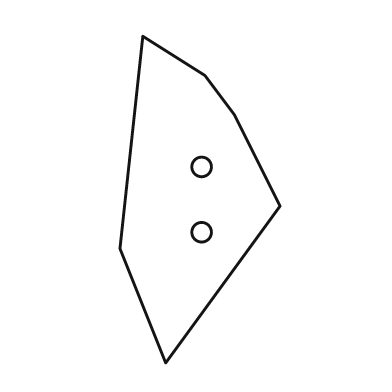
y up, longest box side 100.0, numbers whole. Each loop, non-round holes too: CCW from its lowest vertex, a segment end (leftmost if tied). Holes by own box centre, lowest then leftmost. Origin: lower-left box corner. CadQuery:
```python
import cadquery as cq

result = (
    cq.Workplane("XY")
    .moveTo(14.0, 0.0)
    .lineTo(49.0, 48.0)
    .lineTo(35.0, 76.0)
    .lineTo(26.0, 88.0)
    .lineTo(7.0, 100.0)
    .lineTo(0.0, 35.0)
    .close()
    .moveTo(25.0, 40.0)
    .circle(3.0)
    .moveTo(25.0, 60.0)
    .circle(3.0)
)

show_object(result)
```